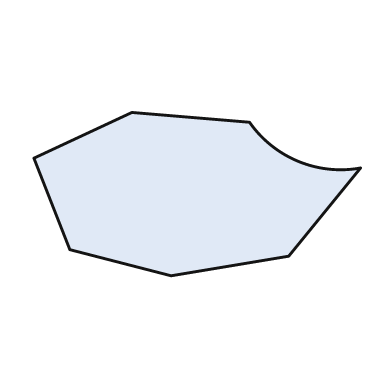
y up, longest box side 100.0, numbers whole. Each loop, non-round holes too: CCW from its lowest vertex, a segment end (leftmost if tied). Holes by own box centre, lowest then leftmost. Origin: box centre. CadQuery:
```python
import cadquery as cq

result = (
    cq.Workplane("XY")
    .moveTo(-8.0, -25.0)
    .lineTo(28.0, -19.0)
    .lineTo(50.0, 8.0)
    .threePointArc((31.0, 10.0), (16.0, 22.0))
    .lineTo(-20.0, 25.0)
    .lineTo(-50.0, 11.0)
    .lineTo(-39.0, -17.0)
    .close()
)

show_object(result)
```